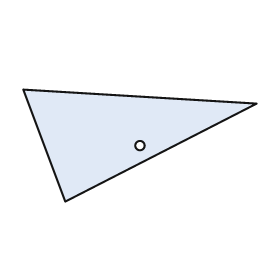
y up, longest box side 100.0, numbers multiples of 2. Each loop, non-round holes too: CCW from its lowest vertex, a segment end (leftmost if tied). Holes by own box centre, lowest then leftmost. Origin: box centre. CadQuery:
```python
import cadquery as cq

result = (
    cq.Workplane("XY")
    .moveTo(-32.0, -24.0)
    .lineTo(50.0, 18.0)
    .lineTo(-50.0, 24.0)
    .close()
    .moveTo(0.0, 0.0)
    .circle(2.0)
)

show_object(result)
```